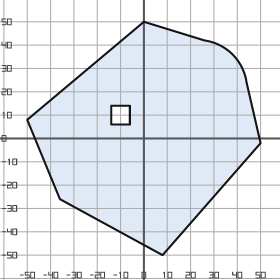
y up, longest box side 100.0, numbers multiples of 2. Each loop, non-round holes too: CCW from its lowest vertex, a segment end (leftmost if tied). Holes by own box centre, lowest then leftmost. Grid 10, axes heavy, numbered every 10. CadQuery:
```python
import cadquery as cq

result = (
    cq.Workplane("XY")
    .moveTo(8.0, -50.0)
    .lineTo(50.0, -2.0)
    .lineTo(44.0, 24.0)
    .threePointArc((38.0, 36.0), (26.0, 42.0))
    .lineTo(0.0, 50.0)
    .lineTo(-50.0, 8.0)
    .lineTo(-36.0, -26.0)
    .close()
    .moveTo(-14.0, 6.0)
    .lineTo(-6.0, 6.0)
    .lineTo(-6.0, 14.0)
    .lineTo(-14.0, 14.0)
    .close()
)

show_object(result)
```